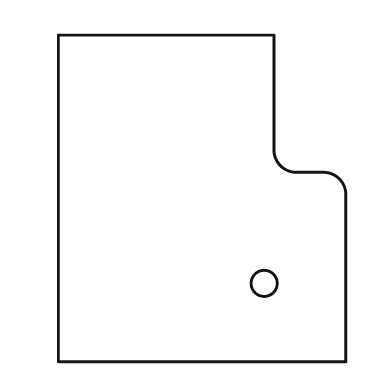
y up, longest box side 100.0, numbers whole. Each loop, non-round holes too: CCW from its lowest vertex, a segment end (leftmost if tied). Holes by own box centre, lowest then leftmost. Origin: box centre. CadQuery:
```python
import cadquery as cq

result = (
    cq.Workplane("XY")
    .moveTo(-44.0, -50.0)
    .lineTo(44.0, -50.0)
    .lineTo(44.0, 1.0)
    .threePointArc((42.0, 6.0), (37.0, 8.0))
    .lineTo(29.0, 8.0)
    .threePointArc((24.0, 10.0), (22.0, 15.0))
    .lineTo(22.0, 50.0)
    .lineTo(-44.0, 50.0)
    .close()
    .moveTo(19.0, -26.0)
    .circle(4.0)
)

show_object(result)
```